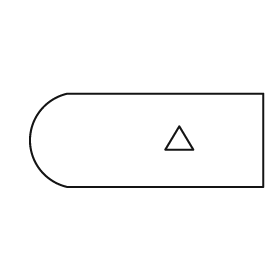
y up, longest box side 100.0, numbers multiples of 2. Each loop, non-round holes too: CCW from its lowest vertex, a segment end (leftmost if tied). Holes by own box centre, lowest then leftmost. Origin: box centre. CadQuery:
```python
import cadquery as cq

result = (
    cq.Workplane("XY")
    .moveTo(-34.0, -20.0)
    .lineTo(50.0, -20.0)
    .lineTo(50.0, 20.0)
    .lineTo(-34.0, 20.0)
    .threePointArc((-50.0, 0.0), (-34.0, -20.0))
    .close()
    .moveTo(8.0, -4.0)
    .lineTo(20.0, -4.0)
    .lineTo(14.0, 6.0)
    .close()
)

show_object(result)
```